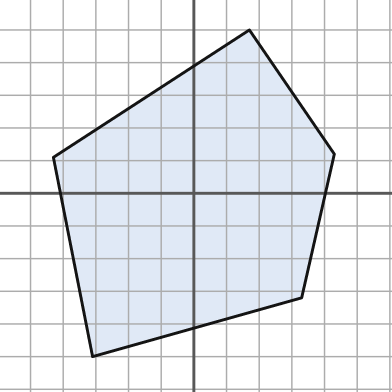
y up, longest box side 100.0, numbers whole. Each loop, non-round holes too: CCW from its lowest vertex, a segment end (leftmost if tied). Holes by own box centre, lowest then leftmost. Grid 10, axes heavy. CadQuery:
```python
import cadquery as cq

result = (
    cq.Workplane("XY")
    .moveTo(-31.0, -50.0)
    .lineTo(33.0, -32.0)
    .lineTo(43.0, 12.0)
    .lineTo(17.0, 50.0)
    .lineTo(-43.0, 11.0)
    .close()
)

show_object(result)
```